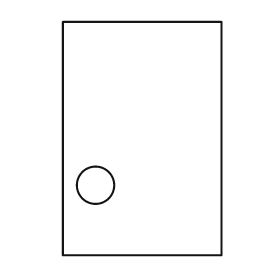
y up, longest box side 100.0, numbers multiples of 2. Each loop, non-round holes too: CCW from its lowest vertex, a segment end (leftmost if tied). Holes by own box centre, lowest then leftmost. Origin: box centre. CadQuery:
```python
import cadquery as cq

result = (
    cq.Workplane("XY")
    .moveTo(-34.0, -50.0)
    .lineTo(34.0, -50.0)
    .lineTo(34.0, 50.0)
    .lineTo(-34.0, 50.0)
    .close()
    .moveTo(-20.0, -20.0)
    .circle(8.0)
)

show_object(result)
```